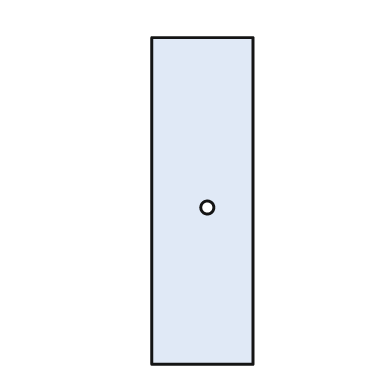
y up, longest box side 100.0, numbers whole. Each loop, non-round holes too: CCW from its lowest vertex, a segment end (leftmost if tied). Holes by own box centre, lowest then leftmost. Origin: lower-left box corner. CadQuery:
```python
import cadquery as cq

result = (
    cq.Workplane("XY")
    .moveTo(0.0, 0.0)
    .lineTo(31.0, 0.0)
    .lineTo(31.0, 100.0)
    .lineTo(0.0, 100.0)
    .close()
    .moveTo(17.0, 48.0)
    .circle(2.0)
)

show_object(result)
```